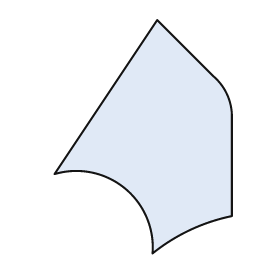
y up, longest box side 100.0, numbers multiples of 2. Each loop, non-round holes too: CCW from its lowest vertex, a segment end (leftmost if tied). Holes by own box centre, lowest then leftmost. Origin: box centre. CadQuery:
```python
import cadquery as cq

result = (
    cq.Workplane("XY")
    .moveTo(4.0, -50.0)
    .threePointArc((20.0, -40.0), (38.0, -34.0))
    .lineTo(38.0, 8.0)
    .threePointArc((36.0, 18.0), (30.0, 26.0))
    .lineTo(6.0, 50.0)
    .lineTo(-38.0, -16.0)
    .threePointArc((-8.0, -22.0), (4.0, -50.0))
    .close()
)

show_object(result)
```